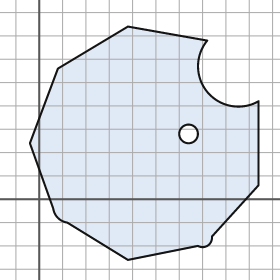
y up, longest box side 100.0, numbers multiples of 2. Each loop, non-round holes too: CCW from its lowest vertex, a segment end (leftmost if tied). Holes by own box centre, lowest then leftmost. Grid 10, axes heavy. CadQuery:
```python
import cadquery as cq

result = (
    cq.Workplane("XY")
    .moveTo(38.0, -26.0)
    .lineTo(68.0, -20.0)
    .threePointArc((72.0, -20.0), (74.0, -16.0))
    .lineTo(94.0, 6.0)
    .lineTo(94.0, 42.0)
    .threePointArc((72.0, 46.0), (72.0, 68.0))
    .lineTo(38.0, 74.0)
    .lineTo(8.0, 56.0)
    .lineTo(-4.0, 24.0)
    .lineTo(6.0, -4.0)
    .threePointArc((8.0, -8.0), (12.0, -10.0))
    .close()
    .moveTo(64.0, 28.0)
    .circle(4.0)
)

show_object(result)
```